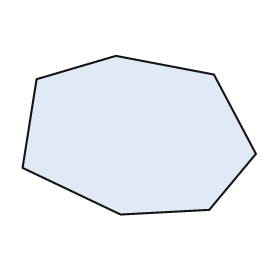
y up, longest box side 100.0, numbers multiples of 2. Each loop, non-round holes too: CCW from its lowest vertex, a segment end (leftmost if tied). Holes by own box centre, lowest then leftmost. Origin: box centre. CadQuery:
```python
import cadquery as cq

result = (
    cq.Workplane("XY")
    .moveTo(-8.0, -34.0)
    .lineTo(30.0, -32.0)
    .lineTo(50.0, -8.0)
    .lineTo(32.0, 26.0)
    .lineTo(-10.0, 34.0)
    .lineTo(-44.0, 24.0)
    .lineTo(-50.0, -14.0)
    .close()
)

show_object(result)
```